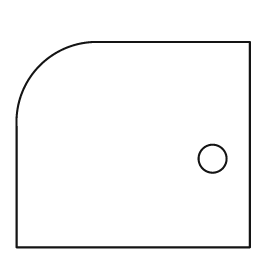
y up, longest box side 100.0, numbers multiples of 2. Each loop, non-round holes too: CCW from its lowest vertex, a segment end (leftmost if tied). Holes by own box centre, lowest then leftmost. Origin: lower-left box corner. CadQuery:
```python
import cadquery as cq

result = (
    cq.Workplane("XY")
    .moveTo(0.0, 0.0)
    .lineTo(100.0, 0.0)
    .lineTo(100.0, 88.0)
    .lineTo(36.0, 88.0)
    .threePointArc((10.0, 78.0), (0.0, 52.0))
    .close()
    .moveTo(84.0, 38.0)
    .circle(6.0)
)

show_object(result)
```